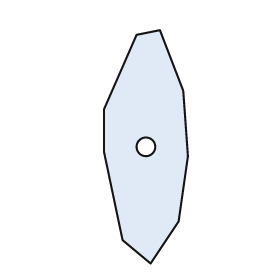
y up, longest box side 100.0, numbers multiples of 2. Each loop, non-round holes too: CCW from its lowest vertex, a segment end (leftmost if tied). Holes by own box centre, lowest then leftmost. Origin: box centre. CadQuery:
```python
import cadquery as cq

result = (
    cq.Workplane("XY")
    .moveTo(2.0, -50.0)
    .lineTo(14.0, -32.0)
    .lineTo(18.0, -4.0)
    .lineTo(16.0, 24.0)
    .lineTo(6.0, 50.0)
    .lineTo(-4.0, 48.0)
    .lineTo(-18.0, 16.0)
    .lineTo(-18.0, -2.0)
    .lineTo(-10.0, -40.0)
    .close()
    .moveTo(0.0, 0.0)
    .circle(4.0)
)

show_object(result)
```